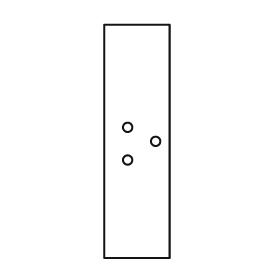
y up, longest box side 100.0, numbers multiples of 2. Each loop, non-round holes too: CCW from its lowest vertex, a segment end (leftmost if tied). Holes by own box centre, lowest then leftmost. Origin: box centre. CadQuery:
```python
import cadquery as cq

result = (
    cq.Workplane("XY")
    .moveTo(-14.0, -50.0)
    .lineTo(14.0, -50.0)
    .lineTo(14.0, 50.0)
    .lineTo(-14.0, 50.0)
    .close()
    .moveTo(-4.0, -8.0)
    .circle(2.0)
    .moveTo(8.0, 0.0)
    .circle(2.0)
    .moveTo(-4.0, 6.0)
    .circle(2.0)
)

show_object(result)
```